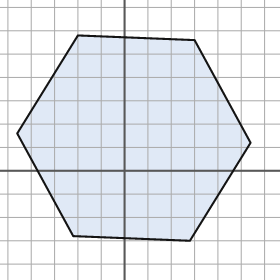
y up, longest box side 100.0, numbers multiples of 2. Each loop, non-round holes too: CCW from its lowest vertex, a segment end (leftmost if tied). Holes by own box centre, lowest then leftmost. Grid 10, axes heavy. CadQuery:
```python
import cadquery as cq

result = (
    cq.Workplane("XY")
    .moveTo(28.0, -30.0)
    .lineTo(54.0, 12.0)
    .lineTo(30.0, 56.0)
    .lineTo(-20.0, 58.0)
    .lineTo(-46.0, 16.0)
    .lineTo(-22.0, -28.0)
    .close()
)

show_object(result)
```